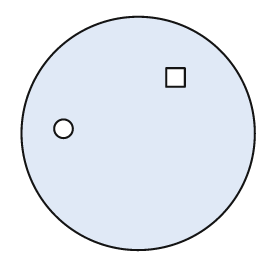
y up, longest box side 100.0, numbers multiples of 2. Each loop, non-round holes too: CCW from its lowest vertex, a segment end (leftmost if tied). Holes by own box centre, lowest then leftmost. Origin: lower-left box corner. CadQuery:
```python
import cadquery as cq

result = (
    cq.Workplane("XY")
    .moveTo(50.0, 50.0)
    .circle(50.0)
    .moveTo(18.0, 52.0)
    .circle(4.0)
    .moveTo(62.0, 70.0)
    .lineTo(70.0, 70.0)
    .lineTo(70.0, 78.0)
    .lineTo(62.0, 78.0)
    .close()
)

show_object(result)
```